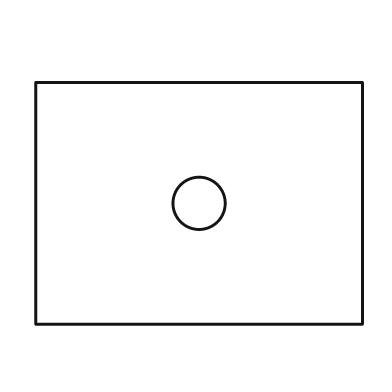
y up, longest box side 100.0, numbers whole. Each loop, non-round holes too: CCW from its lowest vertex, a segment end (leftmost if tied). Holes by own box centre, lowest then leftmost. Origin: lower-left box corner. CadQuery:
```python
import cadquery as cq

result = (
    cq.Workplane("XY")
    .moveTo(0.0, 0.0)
    .lineTo(100.0, 0.0)
    .lineTo(100.0, 74.0)
    .lineTo(0.0, 74.0)
    .close()
    .moveTo(50.0, 37.0)
    .circle(8.0)
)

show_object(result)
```